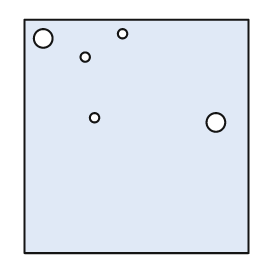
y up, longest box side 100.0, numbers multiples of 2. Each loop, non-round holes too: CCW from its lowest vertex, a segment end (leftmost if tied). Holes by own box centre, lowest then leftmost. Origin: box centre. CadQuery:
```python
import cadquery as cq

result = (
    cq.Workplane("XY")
    .moveTo(-48.0, -50.0)
    .lineTo(48.0, -50.0)
    .lineTo(48.0, 50.0)
    .lineTo(-48.0, 50.0)
    .close()
    .moveTo(34.0, 6.0)
    .circle(4.0)
    .moveTo(-18.0, 8.0)
    .circle(2.0)
    .moveTo(-22.0, 34.0)
    .circle(2.0)
    .moveTo(-40.0, 42.0)
    .circle(4.0)
    .moveTo(-6.0, 44.0)
    .circle(2.0)
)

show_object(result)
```